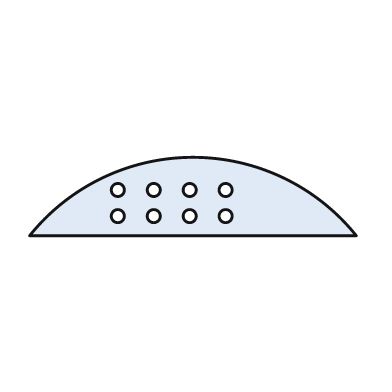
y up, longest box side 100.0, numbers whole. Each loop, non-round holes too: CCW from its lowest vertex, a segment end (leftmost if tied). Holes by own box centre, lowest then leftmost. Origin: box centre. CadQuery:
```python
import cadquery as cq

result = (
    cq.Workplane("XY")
    .moveTo(-50.0, -12.0)
    .lineTo(50.0, -12.0)
    .threePointArc((0.0, 12.0), (-50.0, -12.0))
    .close()
    .moveTo(-23.0, -6.0)
    .circle(2.0)
    .moveTo(-12.0, -6.0)
    .circle(2.0)
    .moveTo(-1.0, -6.0)
    .circle(2.0)
    .moveTo(10.0, -6.0)
    .circle(2.0)
    .moveTo(-23.0, 2.0)
    .circle(2.0)
    .moveTo(-12.0, 2.0)
    .circle(2.0)
    .moveTo(-1.0, 2.0)
    .circle(2.0)
    .moveTo(10.0, 2.0)
    .circle(2.0)
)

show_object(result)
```